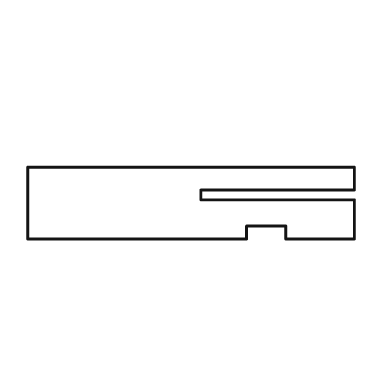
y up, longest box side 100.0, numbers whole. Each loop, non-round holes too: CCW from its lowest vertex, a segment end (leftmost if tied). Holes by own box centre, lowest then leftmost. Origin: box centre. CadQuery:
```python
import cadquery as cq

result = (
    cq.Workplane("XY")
    .moveTo(-50.0, -11.0)
    .lineTo(17.0, -11.0)
    .lineTo(17.0, -7.0)
    .lineTo(29.0, -7.0)
    .lineTo(29.0, -11.0)
    .lineTo(50.0, -11.0)
    .lineTo(50.0, 1.0)
    .lineTo(3.0, 1.0)
    .lineTo(3.0, 4.0)
    .lineTo(50.0, 4.0)
    .lineTo(50.0, 11.0)
    .lineTo(-50.0, 11.0)
    .close()
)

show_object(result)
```